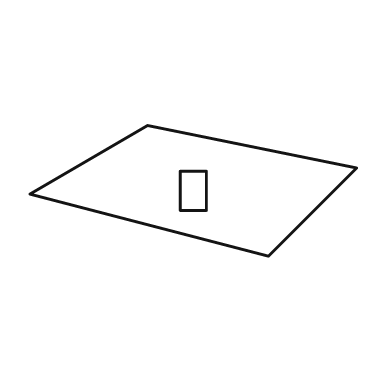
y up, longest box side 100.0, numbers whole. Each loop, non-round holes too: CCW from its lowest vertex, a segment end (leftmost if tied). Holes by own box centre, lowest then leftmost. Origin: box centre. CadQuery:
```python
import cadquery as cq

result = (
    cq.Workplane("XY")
    .moveTo(23.0, -20.0)
    .lineTo(50.0, 7.0)
    .lineTo(-14.0, 20.0)
    .lineTo(-50.0, -1.0)
    .close()
    .moveTo(-4.0, -6.0)
    .lineTo(4.0, -6.0)
    .lineTo(4.0, 6.0)
    .lineTo(-4.0, 6.0)
    .close()
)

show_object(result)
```